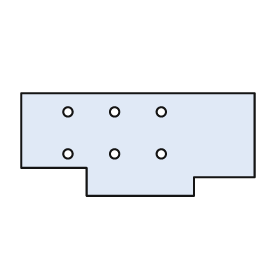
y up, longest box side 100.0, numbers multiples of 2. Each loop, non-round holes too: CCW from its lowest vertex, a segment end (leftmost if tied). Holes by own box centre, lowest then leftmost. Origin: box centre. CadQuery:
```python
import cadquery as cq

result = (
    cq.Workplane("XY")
    .moveTo(-22.0, -22.0)
    .lineTo(24.0, -22.0)
    .lineTo(24.0, -14.0)
    .lineTo(50.0, -14.0)
    .lineTo(50.0, 22.0)
    .lineTo(-50.0, 22.0)
    .lineTo(-50.0, -10.0)
    .lineTo(-22.0, -10.0)
    .close()
    .moveTo(-30.0, -4.0)
    .circle(2.0)
    .moveTo(-10.0, -4.0)
    .circle(2.0)
    .moveTo(10.0, -4.0)
    .circle(2.0)
    .moveTo(-30.0, 14.0)
    .circle(2.0)
    .moveTo(-10.0, 14.0)
    .circle(2.0)
    .moveTo(10.0, 14.0)
    .circle(2.0)
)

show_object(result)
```